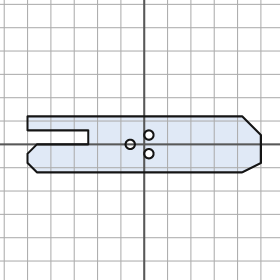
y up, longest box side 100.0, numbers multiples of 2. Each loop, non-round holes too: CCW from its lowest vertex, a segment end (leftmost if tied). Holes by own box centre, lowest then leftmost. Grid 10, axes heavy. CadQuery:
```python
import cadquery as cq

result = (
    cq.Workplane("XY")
    .moveTo(-46.0, -12.0)
    .lineTo(42.0, -12.0)
    .lineTo(50.0, -8.0)
    .lineTo(50.0, 4.0)
    .lineTo(42.0, 12.0)
    .lineTo(-50.0, 12.0)
    .lineTo(-50.0, 6.0)
    .lineTo(-24.0, 6.0)
    .lineTo(-24.0, 0.0)
    .lineTo(-46.0, 0.0)
    .lineTo(-50.0, -4.0)
    .lineTo(-50.0, -8.0)
    .close()
    .moveTo(2.0, -4.0)
    .circle(2.0)
    .moveTo(-6.0, 0.0)
    .circle(2.0)
    .moveTo(2.0, 4.0)
    .circle(2.0)
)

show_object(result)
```